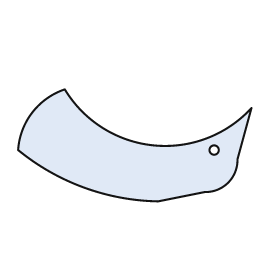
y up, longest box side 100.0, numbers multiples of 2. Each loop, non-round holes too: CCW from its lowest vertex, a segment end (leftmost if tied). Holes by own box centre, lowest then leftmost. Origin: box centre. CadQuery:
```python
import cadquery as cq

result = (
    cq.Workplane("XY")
    .moveTo(10.0, -24.0)
    .lineTo(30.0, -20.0)
    .threePointArc((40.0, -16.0), (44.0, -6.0))
    .lineTo(50.0, 16.0)
    .threePointArc((8.0, 0.0), (-30.0, 24.0))
    .threePointArc((-44.0, 14.0), (-50.0, -2.0))
    .threePointArc((-22.0, -18.0), (10.0, -24.0))
    .close()
    .moveTo(34.0, -2.0)
    .circle(2.0)
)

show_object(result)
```